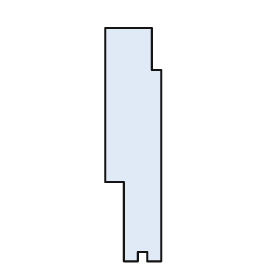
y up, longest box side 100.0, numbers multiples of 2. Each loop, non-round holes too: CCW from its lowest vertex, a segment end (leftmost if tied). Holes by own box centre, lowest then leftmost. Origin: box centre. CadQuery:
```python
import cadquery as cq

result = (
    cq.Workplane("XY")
    .moveTo(-4.0, -50.0)
    .lineTo(2.0, -50.0)
    .lineTo(2.0, -46.0)
    .lineTo(6.0, -46.0)
    .lineTo(6.0, -50.0)
    .lineTo(12.0, -50.0)
    .lineTo(12.0, 32.0)
    .lineTo(8.0, 32.0)
    .lineTo(8.0, 50.0)
    .lineTo(-12.0, 50.0)
    .lineTo(-12.0, -16.0)
    .lineTo(-4.0, -16.0)
    .close()
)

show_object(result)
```